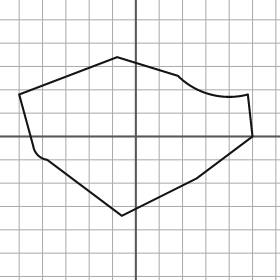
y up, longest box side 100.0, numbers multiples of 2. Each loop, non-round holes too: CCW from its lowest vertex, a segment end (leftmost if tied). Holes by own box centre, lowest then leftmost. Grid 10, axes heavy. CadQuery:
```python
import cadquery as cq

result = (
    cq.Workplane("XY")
    .moveTo(-6.0, -34.0)
    .lineTo(26.0, -18.0)
    .lineTo(50.0, 0.0)
    .lineTo(48.0, 18.0)
    .threePointArc((32.0, 18.0), (18.0, 26.0))
    .lineTo(-8.0, 34.0)
    .lineTo(-50.0, 18.0)
    .lineTo(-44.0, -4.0)
    .threePointArc((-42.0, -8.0), (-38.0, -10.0))
    .close()
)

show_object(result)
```